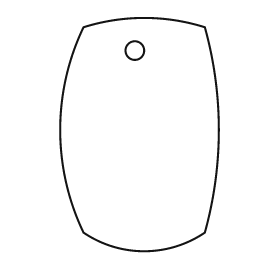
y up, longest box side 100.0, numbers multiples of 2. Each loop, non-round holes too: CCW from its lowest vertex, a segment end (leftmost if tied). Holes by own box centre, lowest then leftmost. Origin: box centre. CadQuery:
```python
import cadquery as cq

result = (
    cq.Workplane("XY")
    .moveTo(-24.0, -42.0)
    .threePointArc((2.0, -50.0), (28.0, -42.0))
    .threePointArc((34.0, 2.0), (28.0, 46.0))
    .threePointArc((2.0, 50.0), (-24.0, 46.0))
    .threePointArc((-34.0, 2.0), (-24.0, -42.0))
    .close()
    .moveTo(-2.0, 36.0)
    .circle(4.0)
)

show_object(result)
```